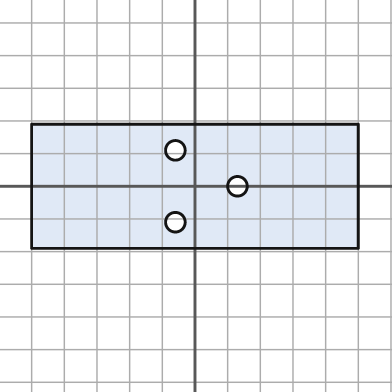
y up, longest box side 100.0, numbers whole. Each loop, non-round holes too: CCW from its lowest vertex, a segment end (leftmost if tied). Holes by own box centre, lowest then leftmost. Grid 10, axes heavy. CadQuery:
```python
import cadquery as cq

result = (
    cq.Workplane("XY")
    .moveTo(-50.0, -19.0)
    .lineTo(50.0, -19.0)
    .lineTo(50.0, 19.0)
    .lineTo(-50.0, 19.0)
    .close()
    .moveTo(-6.0, -11.0)
    .circle(3.0)
    .moveTo(13.0, 0.0)
    .circle(3.0)
    .moveTo(-6.0, 11.0)
    .circle(3.0)
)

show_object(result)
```